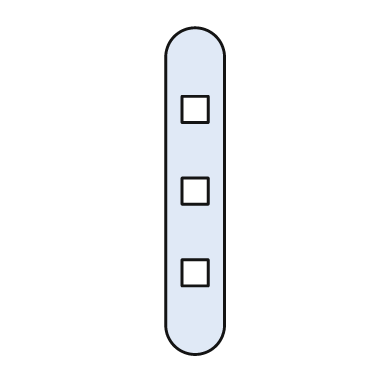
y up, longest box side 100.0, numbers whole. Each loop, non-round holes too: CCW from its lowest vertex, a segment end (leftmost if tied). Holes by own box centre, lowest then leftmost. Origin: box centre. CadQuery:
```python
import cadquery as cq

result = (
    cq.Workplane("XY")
    .moveTo(-9.0, -41.0)
    .threePointArc((0.0, -50.0), (9.0, -41.0))
    .lineTo(9.0, 41.0)
    .threePointArc((0.0, 50.0), (-9.0, 41.0))
    .close()
    .moveTo(-4.0, -29.0)
    .lineTo(4.0, -29.0)
    .lineTo(4.0, -21.0)
    .lineTo(-4.0, -21.0)
    .close()
    .moveTo(-4.0, -4.0)
    .lineTo(4.0, -4.0)
    .lineTo(4.0, 4.0)
    .lineTo(-4.0, 4.0)
    .close()
    .moveTo(-4.0, 21.0)
    .lineTo(4.0, 21.0)
    .lineTo(4.0, 29.0)
    .lineTo(-4.0, 29.0)
    .close()
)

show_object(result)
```